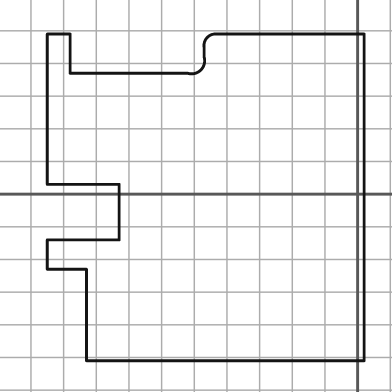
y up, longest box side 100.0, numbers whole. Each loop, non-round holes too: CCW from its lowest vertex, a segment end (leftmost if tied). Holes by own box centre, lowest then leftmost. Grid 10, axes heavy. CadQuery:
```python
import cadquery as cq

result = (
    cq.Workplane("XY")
    .moveTo(-83.0, -51.0)
    .lineTo(2.0, -51.0)
    .lineTo(2.0, 49.0)
    .lineTo(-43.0, 49.0)
    .threePointArc((-46.0, 48.0), (-47.0, 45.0))
    .lineTo(-47.0, 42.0)
    .threePointArc((-48.0, 38.0), (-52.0, 37.0))
    .lineTo(-88.0, 37.0)
    .lineTo(-88.0, 49.0)
    .lineTo(-95.0, 49.0)
    .lineTo(-95.0, 3.0)
    .lineTo(-73.0, 3.0)
    .lineTo(-73.0, -14.0)
    .lineTo(-95.0, -14.0)
    .lineTo(-95.0, -23.0)
    .lineTo(-83.0, -23.0)
    .close()
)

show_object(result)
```